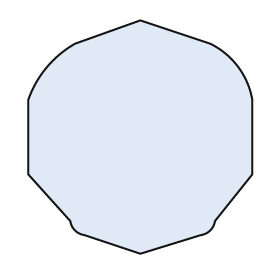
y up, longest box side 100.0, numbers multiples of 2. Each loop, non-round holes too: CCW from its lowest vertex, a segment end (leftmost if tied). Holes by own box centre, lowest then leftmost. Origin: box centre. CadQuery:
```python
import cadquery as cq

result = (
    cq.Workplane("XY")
    .moveTo(0.0, -50.0)
    .lineTo(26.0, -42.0)
    .threePointArc((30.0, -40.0), (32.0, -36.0))
    .lineTo(48.0, -16.0)
    .lineTo(48.0, 16.0)
    .threePointArc((42.0, 30.0), (30.0, 40.0))
    .lineTo(0.0, 50.0)
    .lineTo(-28.0, 40.0)
    .threePointArc((-40.0, 30.0), (-48.0, 16.0))
    .lineTo(-48.0, -16.0)
    .lineTo(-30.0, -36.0)
    .threePointArc((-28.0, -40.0), (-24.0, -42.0))
    .close()
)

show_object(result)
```